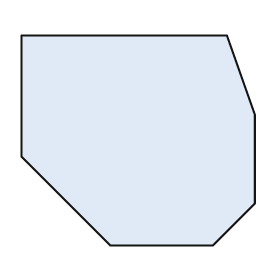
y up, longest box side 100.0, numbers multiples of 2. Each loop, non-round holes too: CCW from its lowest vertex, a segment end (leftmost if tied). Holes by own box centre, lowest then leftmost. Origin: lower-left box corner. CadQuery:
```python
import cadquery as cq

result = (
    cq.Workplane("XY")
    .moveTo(38.0, 0.0)
    .lineTo(82.0, 0.0)
    .lineTo(100.0, 18.0)
    .lineTo(100.0, 56.0)
    .lineTo(88.0, 90.0)
    .lineTo(0.0, 90.0)
    .lineTo(0.0, 38.0)
    .close()
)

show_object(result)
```